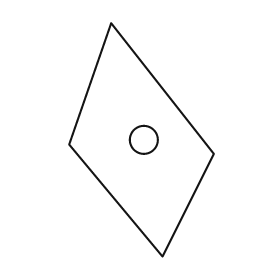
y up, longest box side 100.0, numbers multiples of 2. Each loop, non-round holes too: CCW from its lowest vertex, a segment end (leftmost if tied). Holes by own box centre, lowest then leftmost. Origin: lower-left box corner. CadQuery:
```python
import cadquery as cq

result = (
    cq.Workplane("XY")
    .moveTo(40.0, 0.0)
    .lineTo(62.0, 44.0)
    .lineTo(18.0, 100.0)
    .lineTo(0.0, 48.0)
    .close()
    .moveTo(32.0, 50.0)
    .circle(6.0)
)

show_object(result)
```